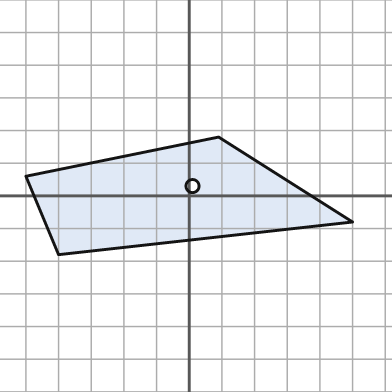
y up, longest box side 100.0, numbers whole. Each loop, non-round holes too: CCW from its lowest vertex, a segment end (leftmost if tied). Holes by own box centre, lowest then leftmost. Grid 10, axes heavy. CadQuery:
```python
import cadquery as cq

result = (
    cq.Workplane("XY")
    .moveTo(-40.0, -18.0)
    .lineTo(50.0, -8.0)
    .lineTo(9.0, 18.0)
    .lineTo(-50.0, 6.0)
    .close()
    .moveTo(1.0, 3.0)
    .circle(2.0)
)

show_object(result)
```